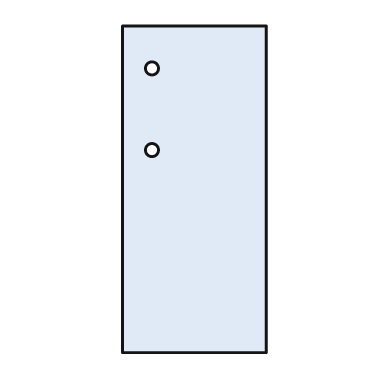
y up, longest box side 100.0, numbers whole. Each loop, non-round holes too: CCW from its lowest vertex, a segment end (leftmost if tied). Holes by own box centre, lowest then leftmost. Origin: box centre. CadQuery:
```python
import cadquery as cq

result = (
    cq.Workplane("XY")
    .moveTo(-22.0, -50.0)
    .lineTo(22.0, -50.0)
    .lineTo(22.0, 50.0)
    .lineTo(-22.0, 50.0)
    .close()
    .moveTo(-13.0, 12.0)
    .circle(2.0)
    .moveTo(-13.0, 37.0)
    .circle(2.0)
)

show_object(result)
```